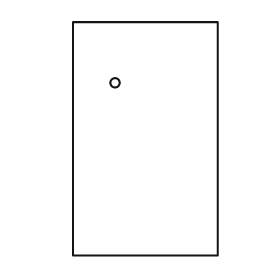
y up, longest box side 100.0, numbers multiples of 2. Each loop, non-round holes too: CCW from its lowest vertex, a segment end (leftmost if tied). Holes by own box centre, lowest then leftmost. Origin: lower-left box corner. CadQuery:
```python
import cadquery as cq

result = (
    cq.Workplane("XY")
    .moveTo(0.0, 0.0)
    .lineTo(62.0, 0.0)
    .lineTo(62.0, 100.0)
    .lineTo(0.0, 100.0)
    .close()
    .moveTo(18.0, 74.0)
    .circle(2.0)
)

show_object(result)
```